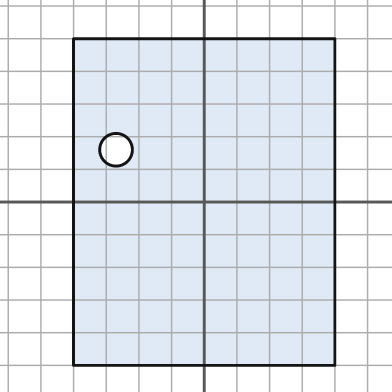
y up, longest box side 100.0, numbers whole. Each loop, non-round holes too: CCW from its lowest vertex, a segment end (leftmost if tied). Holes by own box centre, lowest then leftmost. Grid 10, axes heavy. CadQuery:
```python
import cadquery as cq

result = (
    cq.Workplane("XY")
    .moveTo(-40.0, -50.0)
    .lineTo(40.0, -50.0)
    .lineTo(40.0, 50.0)
    .lineTo(-40.0, 50.0)
    .close()
    .moveTo(-27.0, 16.0)
    .circle(5.0)
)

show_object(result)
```